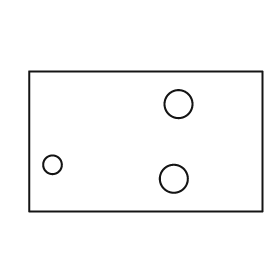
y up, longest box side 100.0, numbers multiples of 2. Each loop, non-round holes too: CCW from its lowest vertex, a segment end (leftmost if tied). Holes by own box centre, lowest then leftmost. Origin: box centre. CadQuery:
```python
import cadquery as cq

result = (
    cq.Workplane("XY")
    .moveTo(-50.0, -30.0)
    .lineTo(50.0, -30.0)
    .lineTo(50.0, 30.0)
    .lineTo(-50.0, 30.0)
    .close()
    .moveTo(12.0, -16.0)
    .circle(6.0)
    .moveTo(-40.0, -10.0)
    .circle(4.0)
    .moveTo(14.0, 16.0)
    .circle(6.0)
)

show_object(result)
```